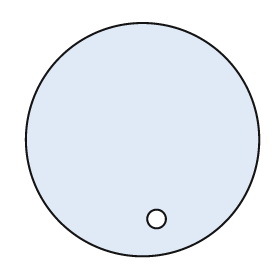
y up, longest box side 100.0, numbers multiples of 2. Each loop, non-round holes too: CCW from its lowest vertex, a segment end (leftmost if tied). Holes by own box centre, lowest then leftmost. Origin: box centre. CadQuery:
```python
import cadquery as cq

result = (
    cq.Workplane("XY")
    .moveTo(0.0, 0.0)
    .circle(50.0)
    .moveTo(6.0, -34.0)
    .circle(4.0)
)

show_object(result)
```